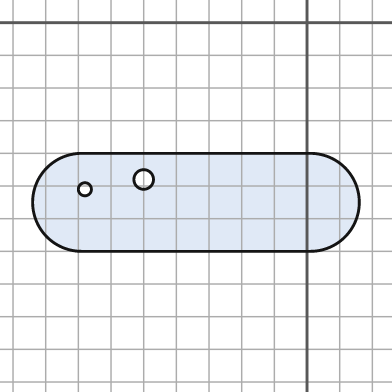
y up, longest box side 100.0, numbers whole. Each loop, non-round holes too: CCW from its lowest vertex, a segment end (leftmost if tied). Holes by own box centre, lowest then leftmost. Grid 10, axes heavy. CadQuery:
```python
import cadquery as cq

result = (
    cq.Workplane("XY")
    .moveTo(-69.0, -70.0)
    .lineTo(1.0, -70.0)
    .threePointArc((16.0, -55.0), (1.0, -40.0))
    .lineTo(-69.0, -40.0)
    .threePointArc((-84.0, -55.0), (-69.0, -70.0))
    .close()
    .moveTo(-68.0, -51.0)
    .circle(2.0)
    .moveTo(-50.0, -48.0)
    .circle(3.0)
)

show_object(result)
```